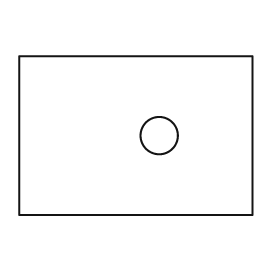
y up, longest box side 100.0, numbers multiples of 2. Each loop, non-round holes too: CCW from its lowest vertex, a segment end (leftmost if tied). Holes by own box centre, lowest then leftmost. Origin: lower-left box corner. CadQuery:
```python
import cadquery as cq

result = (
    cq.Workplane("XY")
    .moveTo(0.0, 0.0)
    .lineTo(100.0, 0.0)
    .lineTo(100.0, 68.0)
    .lineTo(0.0, 68.0)
    .close()
    .moveTo(60.0, 34.0)
    .circle(8.0)
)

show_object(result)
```